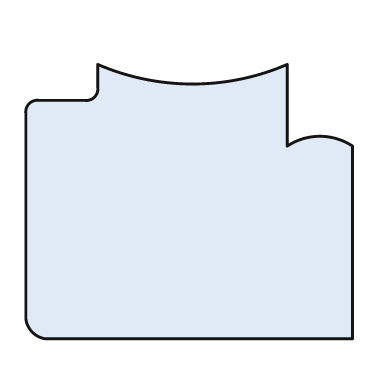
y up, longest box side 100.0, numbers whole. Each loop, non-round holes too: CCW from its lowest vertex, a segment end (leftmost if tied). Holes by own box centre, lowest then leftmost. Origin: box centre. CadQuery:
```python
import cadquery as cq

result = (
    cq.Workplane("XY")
    .moveTo(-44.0, -42.0)
    .lineTo(50.0, -42.0)
    .lineTo(50.0, 17.0)
    .threePointArc((40.0, 20.0), (30.0, 17.0))
    .lineTo(30.0, 42.0)
    .threePointArc((1.0, 36.0), (-28.0, 42.0))
    .lineTo(-28.0, 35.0)
    .threePointArc((-29.0, 32.0), (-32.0, 31.0))
    .lineTo(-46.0, 31.0)
    .threePointArc((-49.0, 30.0), (-50.0, 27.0))
    .lineTo(-50.0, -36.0)
    .threePointArc((-48.0, -40.0), (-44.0, -42.0))
    .close()
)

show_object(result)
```